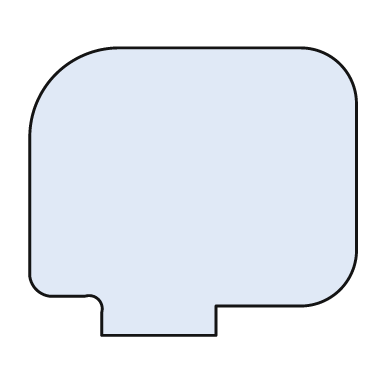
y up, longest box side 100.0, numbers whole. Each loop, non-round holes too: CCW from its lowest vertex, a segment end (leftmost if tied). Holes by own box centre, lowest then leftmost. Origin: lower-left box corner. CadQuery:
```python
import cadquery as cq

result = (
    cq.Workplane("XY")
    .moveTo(22.0, 0.0)
    .lineTo(57.0, 0.0)
    .lineTo(57.0, 9.0)
    .lineTo(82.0, 9.0)
    .threePointArc((95.0, 14.0), (100.0, 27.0))
    .lineTo(100.0, 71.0)
    .threePointArc((95.0, 83.0), (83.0, 88.0))
    .lineTo(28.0, 88.0)
    .threePointArc((8.0, 80.0), (0.0, 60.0))
    .lineTo(0.0, 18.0)
    .threePointArc((2.0, 14.0), (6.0, 12.0))
    .lineTo(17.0, 12.0)
    .threePointArc((21.0, 11.0), (22.0, 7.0))
    .close()
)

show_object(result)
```